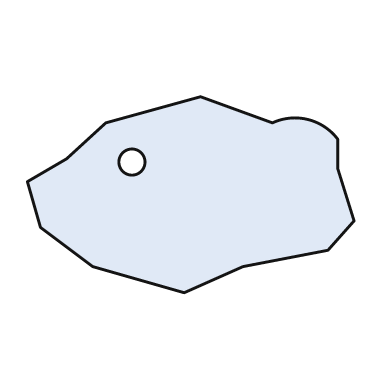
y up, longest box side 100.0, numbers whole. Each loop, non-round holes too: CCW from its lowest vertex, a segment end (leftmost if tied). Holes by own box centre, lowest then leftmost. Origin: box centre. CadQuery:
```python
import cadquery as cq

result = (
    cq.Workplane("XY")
    .moveTo(-2.0, -30.0)
    .lineTo(16.0, -22.0)
    .lineTo(42.0, -17.0)
    .lineTo(50.0, -8.0)
    .lineTo(45.0, 8.0)
    .lineTo(45.0, 17.0)
    .threePointArc((36.0, 23.0), (25.0, 22.0))
    .lineTo(3.0, 30.0)
    .lineTo(-26.0, 22.0)
    .lineTo(-38.0, 11.0)
    .lineTo(-50.0, 4.0)
    .lineTo(-46.0, -10.0)
    .lineTo(-30.0, -22.0)
    .close()
    .moveTo(-18.0, 10.0)
    .circle(4.0)
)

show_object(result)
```